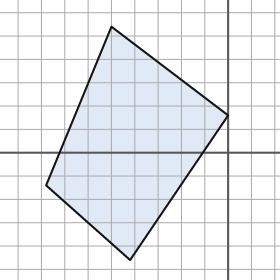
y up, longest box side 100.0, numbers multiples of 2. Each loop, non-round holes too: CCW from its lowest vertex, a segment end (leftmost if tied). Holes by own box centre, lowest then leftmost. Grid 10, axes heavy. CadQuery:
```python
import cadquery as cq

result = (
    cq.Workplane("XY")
    .moveTo(-42.0, -46.0)
    .lineTo(0.0, 16.0)
    .lineTo(-50.0, 54.0)
    .lineTo(-78.0, -14.0)
    .close()
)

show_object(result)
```